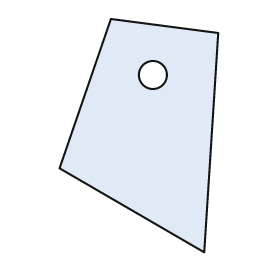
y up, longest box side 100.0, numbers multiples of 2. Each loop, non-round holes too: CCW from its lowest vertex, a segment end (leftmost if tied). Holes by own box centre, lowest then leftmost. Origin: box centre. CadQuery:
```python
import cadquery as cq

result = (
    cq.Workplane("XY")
    .moveTo(28.0, -50.0)
    .lineTo(34.0, 44.0)
    .lineTo(-12.0, 50.0)
    .lineTo(-34.0, -14.0)
    .close()
    .moveTo(6.0, 26.0)
    .circle(6.0)
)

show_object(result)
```